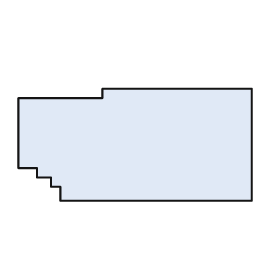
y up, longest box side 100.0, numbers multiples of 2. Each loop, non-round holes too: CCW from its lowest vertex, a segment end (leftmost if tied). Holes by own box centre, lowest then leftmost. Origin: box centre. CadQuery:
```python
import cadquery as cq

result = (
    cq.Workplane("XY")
    .moveTo(-32.0, -24.0)
    .lineTo(50.0, -24.0)
    .lineTo(50.0, 24.0)
    .lineTo(-14.0, 24.0)
    .lineTo(-14.0, 20.0)
    .lineTo(-50.0, 20.0)
    .lineTo(-50.0, -10.0)
    .lineTo(-42.0, -10.0)
    .lineTo(-42.0, -14.0)
    .lineTo(-36.0, -14.0)
    .lineTo(-36.0, -18.0)
    .lineTo(-32.0, -18.0)
    .close()
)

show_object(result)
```